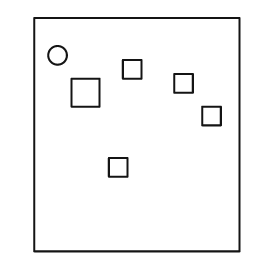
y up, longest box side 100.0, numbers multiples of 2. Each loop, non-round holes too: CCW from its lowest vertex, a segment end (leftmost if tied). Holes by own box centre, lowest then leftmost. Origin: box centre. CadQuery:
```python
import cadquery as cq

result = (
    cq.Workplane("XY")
    .moveTo(-44.0, -50.0)
    .lineTo(44.0, -50.0)
    .lineTo(44.0, 50.0)
    .lineTo(-44.0, 50.0)
    .close()
    .moveTo(-12.0, -18.0)
    .lineTo(-4.0, -18.0)
    .lineTo(-4.0, -10.0)
    .lineTo(-12.0, -10.0)
    .close()
    .moveTo(28.0, 4.0)
    .lineTo(36.0, 4.0)
    .lineTo(36.0, 12.0)
    .lineTo(28.0, 12.0)
    .close()
    .moveTo(-28.0, 12.0)
    .lineTo(-16.0, 12.0)
    .lineTo(-16.0, 24.0)
    .lineTo(-28.0, 24.0)
    .close()
    .moveTo(16.0, 18.0)
    .lineTo(24.0, 18.0)
    .lineTo(24.0, 26.0)
    .lineTo(16.0, 26.0)
    .close()
    .moveTo(-6.0, 24.0)
    .lineTo(2.0, 24.0)
    .lineTo(2.0, 32.0)
    .lineTo(-6.0, 32.0)
    .close()
    .moveTo(-34.0, 34.0)
    .circle(4.0)
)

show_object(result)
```